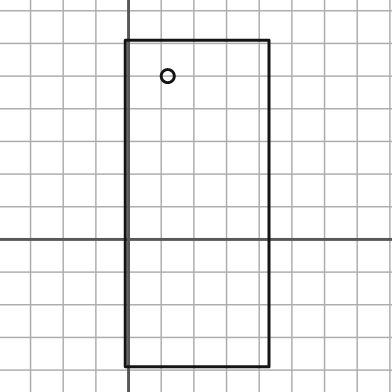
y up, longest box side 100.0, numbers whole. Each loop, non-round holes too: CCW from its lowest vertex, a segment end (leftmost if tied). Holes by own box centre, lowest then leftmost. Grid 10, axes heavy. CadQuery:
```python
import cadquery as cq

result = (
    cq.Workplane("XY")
    .moveTo(-1.0, -39.0)
    .lineTo(43.0, -39.0)
    .lineTo(43.0, 61.0)
    .lineTo(-1.0, 61.0)
    .close()
    .moveTo(12.0, 50.0)
    .circle(2.0)
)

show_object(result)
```